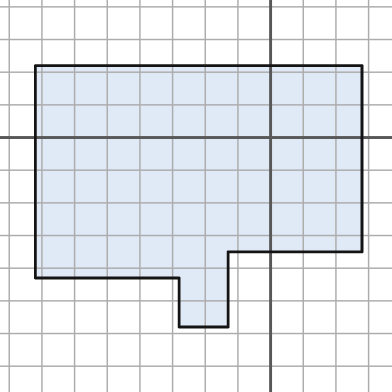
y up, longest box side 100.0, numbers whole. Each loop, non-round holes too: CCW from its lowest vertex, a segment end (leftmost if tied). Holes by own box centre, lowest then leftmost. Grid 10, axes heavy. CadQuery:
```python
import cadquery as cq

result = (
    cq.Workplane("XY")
    .moveTo(-28.0, -58.0)
    .lineTo(-13.0, -58.0)
    .lineTo(-13.0, -35.0)
    .lineTo(28.0, -35.0)
    .lineTo(28.0, 22.0)
    .lineTo(-72.0, 22.0)
    .lineTo(-72.0, -43.0)
    .lineTo(-28.0, -43.0)
    .close()
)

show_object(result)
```